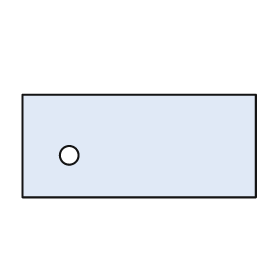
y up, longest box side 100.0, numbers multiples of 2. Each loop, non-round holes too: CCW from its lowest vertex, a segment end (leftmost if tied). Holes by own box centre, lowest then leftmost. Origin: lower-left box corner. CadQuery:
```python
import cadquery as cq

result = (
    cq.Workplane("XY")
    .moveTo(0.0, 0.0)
    .lineTo(100.0, 0.0)
    .lineTo(100.0, 44.0)
    .lineTo(0.0, 44.0)
    .close()
    .moveTo(20.0, 18.0)
    .circle(4.0)
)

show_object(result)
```